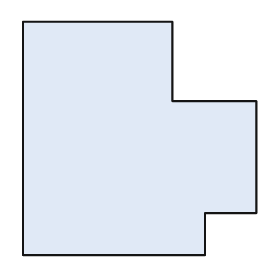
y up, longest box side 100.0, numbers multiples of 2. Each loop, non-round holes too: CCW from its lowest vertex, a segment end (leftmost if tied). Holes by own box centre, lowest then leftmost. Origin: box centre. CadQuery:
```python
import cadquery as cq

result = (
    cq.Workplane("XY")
    .moveTo(-50.0, -50.0)
    .lineTo(28.0, -50.0)
    .lineTo(28.0, -32.0)
    .lineTo(50.0, -32.0)
    .lineTo(50.0, 16.0)
    .lineTo(14.0, 16.0)
    .lineTo(14.0, 50.0)
    .lineTo(-50.0, 50.0)
    .close()
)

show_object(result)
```